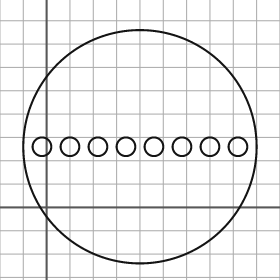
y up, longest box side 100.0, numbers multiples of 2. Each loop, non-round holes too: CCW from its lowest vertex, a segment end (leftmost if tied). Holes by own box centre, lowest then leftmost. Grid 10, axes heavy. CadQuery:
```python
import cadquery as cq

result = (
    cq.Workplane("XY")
    .moveTo(40.0, 26.0)
    .circle(50.0)
    .moveTo(-2.0, 26.0)
    .circle(4.0)
    .moveTo(10.0, 26.0)
    .circle(4.0)
    .moveTo(22.0, 26.0)
    .circle(4.0)
    .moveTo(34.0, 26.0)
    .circle(4.0)
    .moveTo(46.0, 26.0)
    .circle(4.0)
    .moveTo(58.0, 26.0)
    .circle(4.0)
    .moveTo(70.0, 26.0)
    .circle(4.0)
    .moveTo(82.0, 26.0)
    .circle(4.0)
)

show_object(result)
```